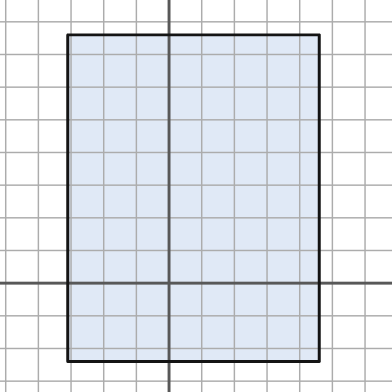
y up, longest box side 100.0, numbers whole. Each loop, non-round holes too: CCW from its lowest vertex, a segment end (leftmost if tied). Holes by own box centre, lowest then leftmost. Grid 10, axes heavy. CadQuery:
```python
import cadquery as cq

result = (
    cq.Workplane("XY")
    .moveTo(-31.0, -24.0)
    .lineTo(46.0, -24.0)
    .lineTo(46.0, 76.0)
    .lineTo(-31.0, 76.0)
    .close()
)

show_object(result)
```